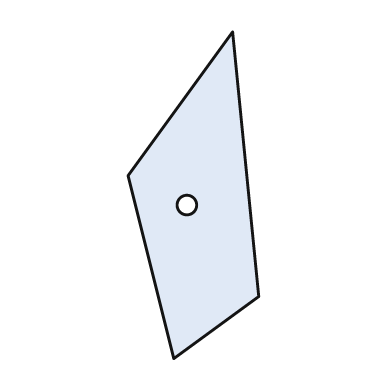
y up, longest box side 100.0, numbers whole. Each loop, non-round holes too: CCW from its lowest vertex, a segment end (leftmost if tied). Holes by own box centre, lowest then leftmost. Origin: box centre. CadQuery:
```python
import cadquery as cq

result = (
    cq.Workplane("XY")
    .moveTo(-6.0, -50.0)
    .lineTo(20.0, -31.0)
    .lineTo(12.0, 50.0)
    .lineTo(-20.0, 6.0)
    .close()
    .moveTo(-2.0, -3.0)
    .circle(3.0)
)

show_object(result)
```